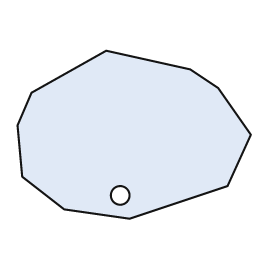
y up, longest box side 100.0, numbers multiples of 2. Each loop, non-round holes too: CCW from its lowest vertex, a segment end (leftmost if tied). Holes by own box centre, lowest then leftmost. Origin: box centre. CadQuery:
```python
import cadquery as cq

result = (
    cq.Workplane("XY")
    .moveTo(-2.0, -36.0)
    .lineTo(40.0, -22.0)
    .lineTo(50.0, 0.0)
    .lineTo(36.0, 20.0)
    .lineTo(24.0, 28.0)
    .lineTo(-12.0, 36.0)
    .lineTo(-44.0, 18.0)
    .lineTo(-50.0, 4.0)
    .lineTo(-48.0, -18.0)
    .lineTo(-30.0, -32.0)
    .close()
    .moveTo(-6.0, -26.0)
    .circle(4.0)
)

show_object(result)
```